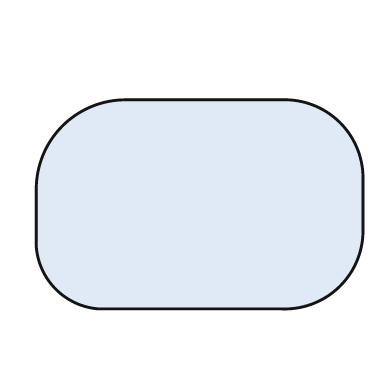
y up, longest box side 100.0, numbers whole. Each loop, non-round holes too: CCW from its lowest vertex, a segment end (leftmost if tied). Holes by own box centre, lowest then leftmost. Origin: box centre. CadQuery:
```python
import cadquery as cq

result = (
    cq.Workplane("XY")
    .moveTo(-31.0, -32.0)
    .lineTo(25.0, -32.0)
    .threePointArc((43.0, -25.0), (50.0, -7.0))
    .lineTo(50.0, 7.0)
    .threePointArc((43.0, 25.0), (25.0, 32.0))
    .lineTo(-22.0, 32.0)
    .threePointArc((-42.0, 24.0), (-50.0, 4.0))
    .lineTo(-50.0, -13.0)
    .threePointArc((-44.0, -26.0), (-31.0, -32.0))
    .close()
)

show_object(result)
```